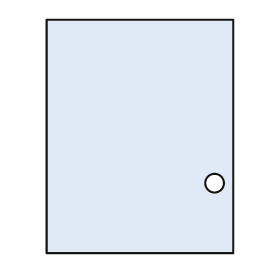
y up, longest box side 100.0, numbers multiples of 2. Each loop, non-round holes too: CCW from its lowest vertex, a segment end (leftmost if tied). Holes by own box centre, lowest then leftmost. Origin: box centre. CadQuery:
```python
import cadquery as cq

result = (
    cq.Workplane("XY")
    .moveTo(-40.0, -50.0)
    .lineTo(40.0, -50.0)
    .lineTo(40.0, 50.0)
    .lineTo(-40.0, 50.0)
    .close()
    .moveTo(32.0, -20.0)
    .circle(4.0)
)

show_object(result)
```